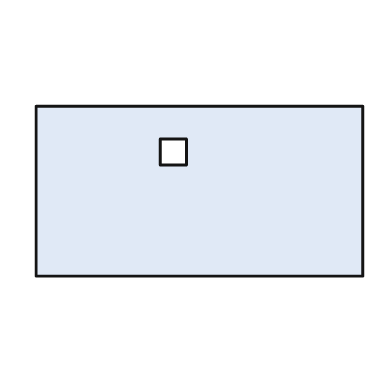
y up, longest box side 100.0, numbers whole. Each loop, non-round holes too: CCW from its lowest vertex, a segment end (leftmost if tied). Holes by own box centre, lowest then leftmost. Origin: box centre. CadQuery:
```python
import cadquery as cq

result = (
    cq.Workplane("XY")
    .moveTo(-50.0, -26.0)
    .lineTo(50.0, -26.0)
    .lineTo(50.0, 26.0)
    .lineTo(-50.0, 26.0)
    .close()
    .moveTo(-12.0, 8.0)
    .lineTo(-4.0, 8.0)
    .lineTo(-4.0, 16.0)
    .lineTo(-12.0, 16.0)
    .close()
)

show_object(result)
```